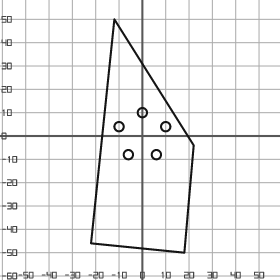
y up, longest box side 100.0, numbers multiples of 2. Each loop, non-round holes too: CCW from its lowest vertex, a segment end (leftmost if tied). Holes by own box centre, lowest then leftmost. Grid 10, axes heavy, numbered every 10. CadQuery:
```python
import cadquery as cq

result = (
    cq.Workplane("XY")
    .moveTo(18.0, -50.0)
    .lineTo(22.0, -4.0)
    .lineTo(-12.0, 50.0)
    .lineTo(-22.0, -46.0)
    .close()
    .moveTo(-6.0, -8.0)
    .circle(2.0)
    .moveTo(6.0, -8.0)
    .circle(2.0)
    .moveTo(-10.0, 4.0)
    .circle(2.0)
    .moveTo(10.0, 4.0)
    .circle(2.0)
    .moveTo(0.0, 10.0)
    .circle(2.0)
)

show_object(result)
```